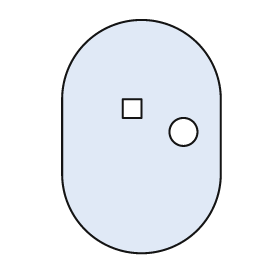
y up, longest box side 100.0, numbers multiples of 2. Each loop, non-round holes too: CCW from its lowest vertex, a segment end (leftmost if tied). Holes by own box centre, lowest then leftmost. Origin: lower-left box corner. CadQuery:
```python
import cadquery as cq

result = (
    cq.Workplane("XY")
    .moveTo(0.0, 34.0)
    .threePointArc((34.0, 0.0), (68.0, 34.0))
    .lineTo(68.0, 66.0)
    .threePointArc((34.0, 100.0), (0.0, 66.0))
    .close()
    .moveTo(52.0, 52.0)
    .circle(6.0)
    .moveTo(26.0, 58.0)
    .lineTo(34.0, 58.0)
    .lineTo(34.0, 66.0)
    .lineTo(26.0, 66.0)
    .close()
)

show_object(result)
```